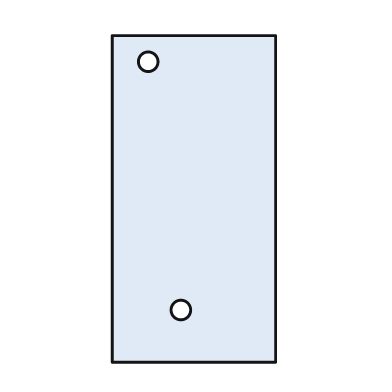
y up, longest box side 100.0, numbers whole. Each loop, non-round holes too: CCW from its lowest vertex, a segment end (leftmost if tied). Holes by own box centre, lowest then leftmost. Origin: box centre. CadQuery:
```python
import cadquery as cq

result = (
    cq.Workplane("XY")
    .moveTo(-25.0, -50.0)
    .lineTo(25.0, -50.0)
    .lineTo(25.0, 50.0)
    .lineTo(-25.0, 50.0)
    .close()
    .moveTo(-4.0, -34.0)
    .circle(3.0)
    .moveTo(-14.0, 42.0)
    .circle(3.0)
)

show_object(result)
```